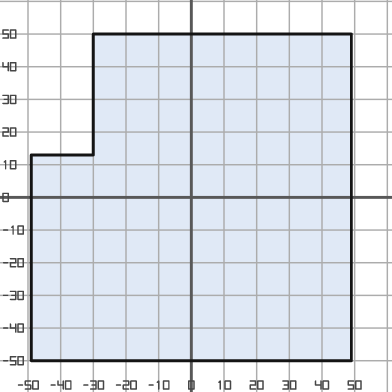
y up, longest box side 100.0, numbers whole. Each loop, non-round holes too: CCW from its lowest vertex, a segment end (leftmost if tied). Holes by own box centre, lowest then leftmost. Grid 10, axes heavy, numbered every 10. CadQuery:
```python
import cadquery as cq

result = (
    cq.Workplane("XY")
    .moveTo(-49.0, -50.0)
    .lineTo(49.0, -50.0)
    .lineTo(49.0, 50.0)
    .lineTo(-30.0, 50.0)
    .lineTo(-30.0, 13.0)
    .lineTo(-49.0, 13.0)
    .close()
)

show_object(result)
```